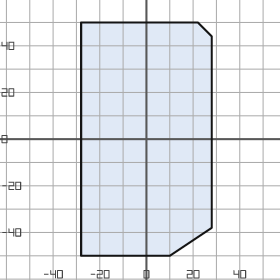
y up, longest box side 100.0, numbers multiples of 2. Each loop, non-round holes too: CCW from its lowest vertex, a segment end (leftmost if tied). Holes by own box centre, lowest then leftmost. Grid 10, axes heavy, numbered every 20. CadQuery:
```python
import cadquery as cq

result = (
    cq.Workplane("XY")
    .moveTo(-28.0, -50.0)
    .lineTo(10.0, -50.0)
    .lineTo(28.0, -38.0)
    .lineTo(28.0, 44.0)
    .lineTo(22.0, 50.0)
    .lineTo(-28.0, 50.0)
    .close()
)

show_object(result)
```